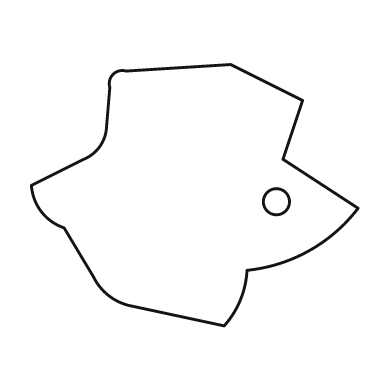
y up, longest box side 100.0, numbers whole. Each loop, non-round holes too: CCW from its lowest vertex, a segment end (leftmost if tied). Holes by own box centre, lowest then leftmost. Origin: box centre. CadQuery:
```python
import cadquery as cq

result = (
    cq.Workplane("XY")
    .moveTo(9.0, -40.0)
    .threePointArc((14.0, -32.0), (16.0, -23.0))
    .threePointArc((35.0, -17.0), (50.0, -4.0))
    .lineTo(27.0, 11.0)
    .lineTo(33.0, 29.0)
    .lineTo(11.0, 40.0)
    .lineTo(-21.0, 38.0)
    .threePointArc((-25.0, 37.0), (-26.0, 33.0))
    .lineTo(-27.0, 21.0)
    .threePointArc((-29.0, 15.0), (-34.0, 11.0))
    .lineTo(-50.0, 3.0)
    .threePointArc((-47.0, -5.0), (-40.0, -10.0))
    .lineTo(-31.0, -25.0)
    .threePointArc((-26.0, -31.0), (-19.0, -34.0))
    .close()
    .moveTo(25.0, -2.0)
    .circle(4.0)
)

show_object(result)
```